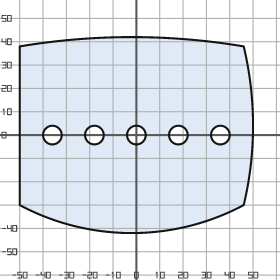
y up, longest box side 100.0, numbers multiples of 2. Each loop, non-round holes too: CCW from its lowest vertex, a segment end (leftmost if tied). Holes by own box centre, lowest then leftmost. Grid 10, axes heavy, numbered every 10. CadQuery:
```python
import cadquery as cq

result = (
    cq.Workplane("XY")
    .moveTo(-50.0, -30.0)
    .threePointArc((-2.0, -42.0), (46.0, -30.0))
    .threePointArc((50.0, 4.0), (46.0, 38.0))
    .threePointArc((-2.0, 42.0), (-50.0, 38.0))
    .close()
    .moveTo(-36.0, 0.0)
    .circle(4.0)
    .moveTo(-18.0, 0.0)
    .circle(4.0)
    .moveTo(0.0, 0.0)
    .circle(4.0)
    .moveTo(18.0, 0.0)
    .circle(4.0)
    .moveTo(36.0, 0.0)
    .circle(4.0)
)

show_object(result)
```